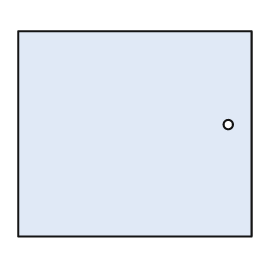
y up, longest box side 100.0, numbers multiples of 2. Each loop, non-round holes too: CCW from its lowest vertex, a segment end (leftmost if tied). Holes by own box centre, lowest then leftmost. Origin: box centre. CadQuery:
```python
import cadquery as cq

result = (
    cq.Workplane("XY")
    .moveTo(-50.0, -44.0)
    .lineTo(50.0, -44.0)
    .lineTo(50.0, 44.0)
    .lineTo(-50.0, 44.0)
    .close()
    .moveTo(40.0, 4.0)
    .circle(2.0)
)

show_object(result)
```